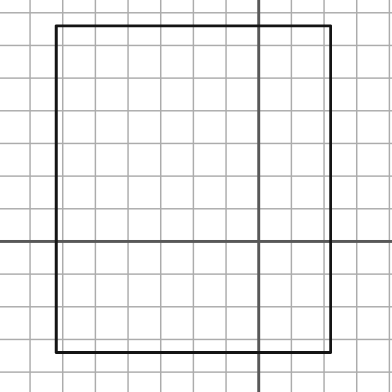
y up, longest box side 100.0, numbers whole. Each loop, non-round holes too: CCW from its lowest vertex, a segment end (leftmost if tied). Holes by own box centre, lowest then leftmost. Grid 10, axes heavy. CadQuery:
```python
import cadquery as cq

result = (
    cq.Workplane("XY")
    .moveTo(-62.0, -34.0)
    .lineTo(22.0, -34.0)
    .lineTo(22.0, 66.0)
    .lineTo(-62.0, 66.0)
    .close()
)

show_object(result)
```